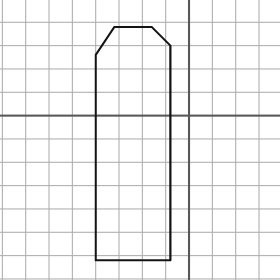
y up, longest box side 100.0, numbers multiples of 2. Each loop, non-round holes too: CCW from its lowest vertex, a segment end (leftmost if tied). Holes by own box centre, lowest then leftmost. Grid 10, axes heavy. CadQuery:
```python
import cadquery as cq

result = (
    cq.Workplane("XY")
    .moveTo(-40.0, -62.0)
    .lineTo(-8.0, -62.0)
    .lineTo(-8.0, 30.0)
    .lineTo(-16.0, 38.0)
    .lineTo(-32.0, 38.0)
    .lineTo(-40.0, 26.0)
    .close()
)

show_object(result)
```